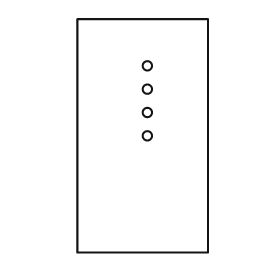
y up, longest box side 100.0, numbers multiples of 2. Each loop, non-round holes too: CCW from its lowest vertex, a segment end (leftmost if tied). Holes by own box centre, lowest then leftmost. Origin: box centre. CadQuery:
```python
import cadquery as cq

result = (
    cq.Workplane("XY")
    .moveTo(-28.0, -50.0)
    .lineTo(28.0, -50.0)
    .lineTo(28.0, 50.0)
    .lineTo(-28.0, 50.0)
    .close()
    .moveTo(2.0, 0.0)
    .circle(2.0)
    .moveTo(2.0, 10.0)
    .circle(2.0)
    .moveTo(2.0, 20.0)
    .circle(2.0)
    .moveTo(2.0, 30.0)
    .circle(2.0)
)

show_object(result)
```